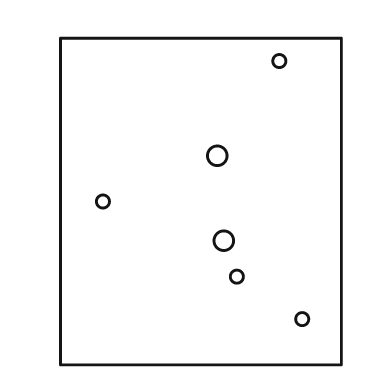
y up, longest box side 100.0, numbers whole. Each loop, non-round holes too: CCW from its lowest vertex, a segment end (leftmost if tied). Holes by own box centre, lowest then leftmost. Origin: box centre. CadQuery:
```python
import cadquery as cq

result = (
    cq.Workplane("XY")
    .moveTo(-43.0, -50.0)
    .lineTo(43.0, -50.0)
    .lineTo(43.0, 50.0)
    .lineTo(-43.0, 50.0)
    .close()
    .moveTo(31.0, -36.0)
    .circle(2.0)
    .moveTo(11.0, -23.0)
    .circle(2.0)
    .moveTo(7.0, -12.0)
    .circle(3.0)
    .moveTo(-30.0, 0.0)
    .circle(2.0)
    .moveTo(5.0, 14.0)
    .circle(3.0)
    .moveTo(24.0, 43.0)
    .circle(2.0)
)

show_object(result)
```